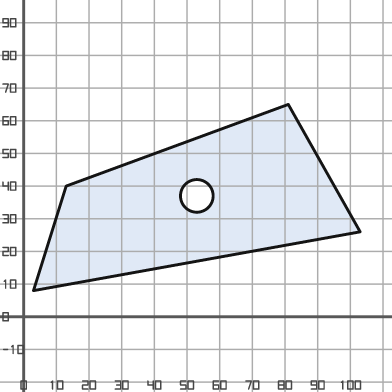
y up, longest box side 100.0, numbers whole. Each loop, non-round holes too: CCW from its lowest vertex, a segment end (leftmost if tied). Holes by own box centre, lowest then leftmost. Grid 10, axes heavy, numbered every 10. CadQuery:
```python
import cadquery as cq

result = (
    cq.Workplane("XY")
    .moveTo(3.0, 8.0)
    .lineTo(103.0, 26.0)
    .lineTo(81.0, 65.0)
    .lineTo(13.0, 40.0)
    .close()
    .moveTo(53.0, 37.0)
    .circle(5.0)
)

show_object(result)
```